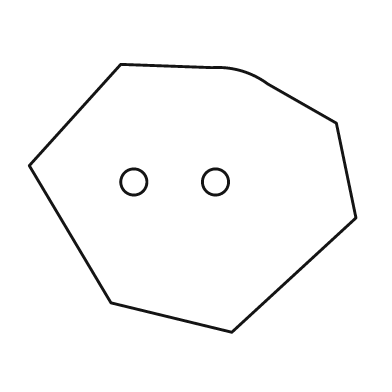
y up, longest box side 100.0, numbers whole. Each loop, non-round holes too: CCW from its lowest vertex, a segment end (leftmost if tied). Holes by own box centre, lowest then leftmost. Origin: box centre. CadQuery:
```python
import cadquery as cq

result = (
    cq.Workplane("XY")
    .moveTo(12.0, -41.0)
    .lineTo(50.0, -6.0)
    .lineTo(44.0, 23.0)
    .lineTo(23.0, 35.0)
    .threePointArc((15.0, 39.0), (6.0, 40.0))
    .lineTo(-22.0, 41.0)
    .lineTo(-50.0, 10.0)
    .lineTo(-25.0, -32.0)
    .close()
    .moveTo(-18.0, 5.0)
    .circle(4.0)
    .moveTo(7.0, 5.0)
    .circle(4.0)
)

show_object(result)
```